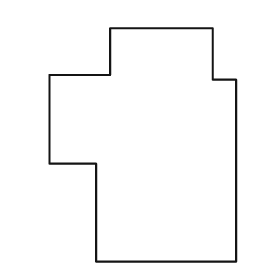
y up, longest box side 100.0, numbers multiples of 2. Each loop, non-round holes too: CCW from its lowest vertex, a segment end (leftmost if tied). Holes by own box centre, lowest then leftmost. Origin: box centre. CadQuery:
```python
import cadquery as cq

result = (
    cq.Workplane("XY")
    .moveTo(-20.0, -50.0)
    .lineTo(40.0, -50.0)
    .lineTo(40.0, 28.0)
    .lineTo(30.0, 28.0)
    .lineTo(30.0, 50.0)
    .lineTo(-14.0, 50.0)
    .lineTo(-14.0, 30.0)
    .lineTo(-40.0, 30.0)
    .lineTo(-40.0, -8.0)
    .lineTo(-20.0, -8.0)
    .close()
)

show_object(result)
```